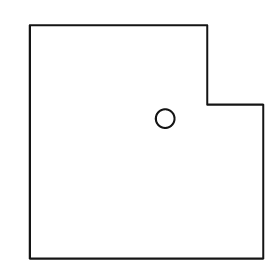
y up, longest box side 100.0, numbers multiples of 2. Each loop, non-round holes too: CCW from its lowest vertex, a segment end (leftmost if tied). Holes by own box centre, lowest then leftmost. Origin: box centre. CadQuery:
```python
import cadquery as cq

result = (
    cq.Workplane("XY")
    .moveTo(-50.0, -50.0)
    .lineTo(50.0, -50.0)
    .lineTo(50.0, 16.0)
    .lineTo(26.0, 16.0)
    .lineTo(26.0, 50.0)
    .lineTo(-50.0, 50.0)
    .close()
    .moveTo(8.0, 10.0)
    .circle(4.0)
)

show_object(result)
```